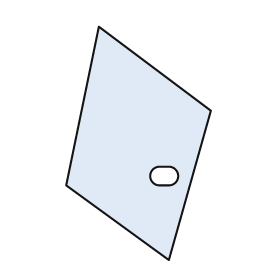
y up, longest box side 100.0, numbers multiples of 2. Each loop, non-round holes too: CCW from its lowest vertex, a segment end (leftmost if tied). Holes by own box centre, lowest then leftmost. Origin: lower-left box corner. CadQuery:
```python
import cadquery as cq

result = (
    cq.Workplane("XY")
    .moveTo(44.0, 0.0)
    .lineTo(62.0, 64.0)
    .lineTo(14.0, 100.0)
    .lineTo(0.0, 32.0)
    .close()
    .moveTo(40.0, 32.0)
    .lineTo(44.0, 32.0)
    .threePointArc((48.0, 36.0), (44.0, 40.0))
    .lineTo(40.0, 40.0)
    .threePointArc((36.0, 36.0), (40.0, 32.0))
    .close()
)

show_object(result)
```